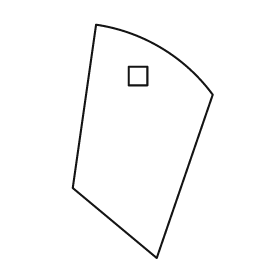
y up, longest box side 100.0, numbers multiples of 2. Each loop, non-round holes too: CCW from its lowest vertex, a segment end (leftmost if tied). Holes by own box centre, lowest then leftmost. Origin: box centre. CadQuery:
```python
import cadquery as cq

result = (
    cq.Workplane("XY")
    .moveTo(6.0, -50.0)
    .lineTo(30.0, 20.0)
    .threePointArc((8.0, 40.0), (-20.0, 50.0))
    .lineTo(-30.0, -20.0)
    .close()
    .moveTo(-6.0, 24.0)
    .lineTo(2.0, 24.0)
    .lineTo(2.0, 32.0)
    .lineTo(-6.0, 32.0)
    .close()
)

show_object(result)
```